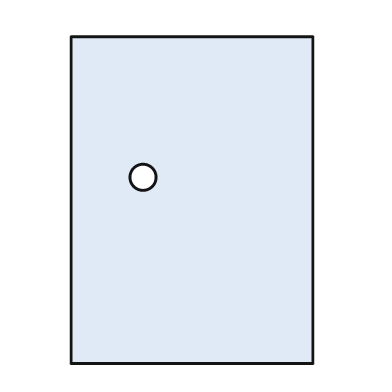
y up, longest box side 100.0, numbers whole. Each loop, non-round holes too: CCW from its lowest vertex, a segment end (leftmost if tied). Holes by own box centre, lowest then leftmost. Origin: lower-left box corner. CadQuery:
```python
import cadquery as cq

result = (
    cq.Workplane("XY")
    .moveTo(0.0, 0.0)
    .lineTo(74.0, 0.0)
    .lineTo(74.0, 100.0)
    .lineTo(0.0, 100.0)
    .close()
    .moveTo(22.0, 57.0)
    .circle(4.0)
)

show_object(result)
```